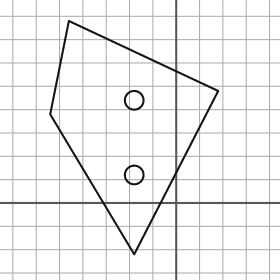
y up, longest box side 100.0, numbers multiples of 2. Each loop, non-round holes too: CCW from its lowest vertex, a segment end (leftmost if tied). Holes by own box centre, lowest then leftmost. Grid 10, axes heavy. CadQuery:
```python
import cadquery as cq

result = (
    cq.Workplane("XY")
    .moveTo(-18.0, -22.0)
    .lineTo(18.0, 48.0)
    .lineTo(-46.0, 78.0)
    .lineTo(-54.0, 38.0)
    .close()
    .moveTo(-18.0, 12.0)
    .circle(4.0)
    .moveTo(-18.0, 44.0)
    .circle(4.0)
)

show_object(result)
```